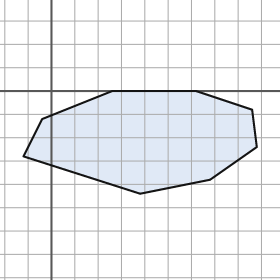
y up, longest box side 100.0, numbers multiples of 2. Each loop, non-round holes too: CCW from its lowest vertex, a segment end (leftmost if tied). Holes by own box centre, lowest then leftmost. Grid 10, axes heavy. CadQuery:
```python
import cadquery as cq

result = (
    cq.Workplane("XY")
    .moveTo(38.0, -44.0)
    .lineTo(68.0, -38.0)
    .lineTo(88.0, -24.0)
    .lineTo(86.0, -8.0)
    .lineTo(62.0, 0.0)
    .lineTo(26.0, 0.0)
    .lineTo(-4.0, -12.0)
    .lineTo(-12.0, -28.0)
    .close()
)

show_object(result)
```